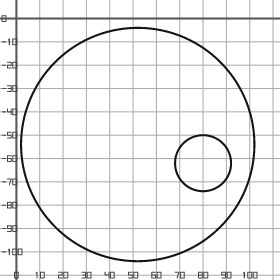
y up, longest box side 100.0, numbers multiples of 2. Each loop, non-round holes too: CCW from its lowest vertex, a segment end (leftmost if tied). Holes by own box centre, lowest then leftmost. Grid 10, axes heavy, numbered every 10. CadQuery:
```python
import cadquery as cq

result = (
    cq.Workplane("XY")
    .moveTo(52.0, -54.0)
    .circle(50.0)
    .moveTo(80.0, -62.0)
    .circle(12.0)
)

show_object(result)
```